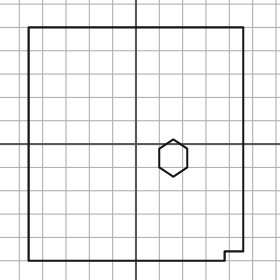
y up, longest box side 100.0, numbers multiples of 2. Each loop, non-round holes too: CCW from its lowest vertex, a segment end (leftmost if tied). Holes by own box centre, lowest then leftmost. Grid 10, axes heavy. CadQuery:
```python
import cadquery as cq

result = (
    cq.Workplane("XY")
    .moveTo(-46.0, -50.0)
    .lineTo(38.0, -50.0)
    .lineTo(38.0, -46.0)
    .lineTo(46.0, -46.0)
    .lineTo(46.0, 50.0)
    .lineTo(-46.0, 50.0)
    .close()
    .moveTo(16.0, -14.0)
    .lineTo(22.0, -10.0)
    .lineTo(22.0, -2.0)
    .lineTo(16.0, 2.0)
    .lineTo(10.0, -2.0)
    .lineTo(10.0, -10.0)
    .close()
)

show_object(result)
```